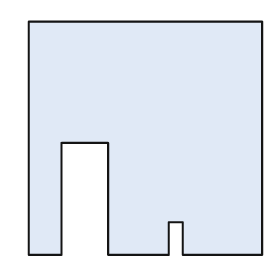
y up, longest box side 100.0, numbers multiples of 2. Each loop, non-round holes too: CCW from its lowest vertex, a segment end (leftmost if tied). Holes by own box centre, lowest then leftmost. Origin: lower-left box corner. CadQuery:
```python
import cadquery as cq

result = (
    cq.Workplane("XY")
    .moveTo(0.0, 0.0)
    .lineTo(14.0, 0.0)
    .lineTo(14.0, 48.0)
    .lineTo(34.0, 48.0)
    .lineTo(34.0, 0.0)
    .lineTo(60.0, 0.0)
    .lineTo(60.0, 14.0)
    .lineTo(66.0, 14.0)
    .lineTo(66.0, 0.0)
    .lineTo(100.0, 0.0)
    .lineTo(100.0, 100.0)
    .lineTo(0.0, 100.0)
    .close()
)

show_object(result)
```